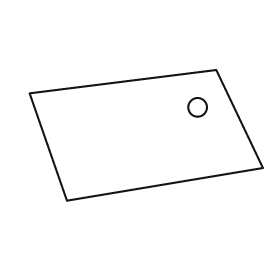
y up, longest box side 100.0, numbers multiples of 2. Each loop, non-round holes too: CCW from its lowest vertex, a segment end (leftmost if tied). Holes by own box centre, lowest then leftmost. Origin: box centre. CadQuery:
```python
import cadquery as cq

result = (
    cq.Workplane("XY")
    .moveTo(-34.0, -28.0)
    .lineTo(50.0, -14.0)
    .lineTo(30.0, 28.0)
    .lineTo(-50.0, 18.0)
    .close()
    .moveTo(22.0, 12.0)
    .circle(4.0)
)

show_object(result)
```